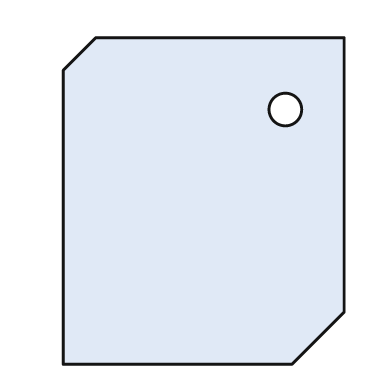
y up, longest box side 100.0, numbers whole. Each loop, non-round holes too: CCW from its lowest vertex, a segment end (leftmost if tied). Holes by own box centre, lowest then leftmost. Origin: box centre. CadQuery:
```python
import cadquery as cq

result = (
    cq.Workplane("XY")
    .moveTo(-43.0, -50.0)
    .lineTo(27.0, -50.0)
    .lineTo(43.0, -34.0)
    .lineTo(43.0, 50.0)
    .lineTo(-33.0, 50.0)
    .lineTo(-43.0, 40.0)
    .close()
    .moveTo(25.0, 28.0)
    .circle(5.0)
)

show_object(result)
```